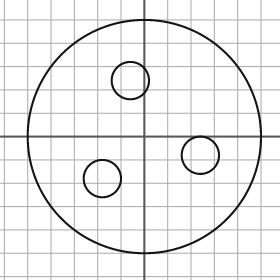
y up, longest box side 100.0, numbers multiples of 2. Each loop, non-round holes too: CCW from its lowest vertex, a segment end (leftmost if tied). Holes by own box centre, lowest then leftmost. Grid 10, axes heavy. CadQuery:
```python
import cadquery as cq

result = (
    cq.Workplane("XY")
    .moveTo(0.0, 0.0)
    .circle(50.0)
    .moveTo(-18.0, -18.0)
    .circle(8.0)
    .moveTo(24.0, -8.0)
    .circle(8.0)
    .moveTo(-6.0, 24.0)
    .circle(8.0)
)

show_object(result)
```